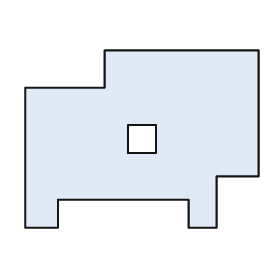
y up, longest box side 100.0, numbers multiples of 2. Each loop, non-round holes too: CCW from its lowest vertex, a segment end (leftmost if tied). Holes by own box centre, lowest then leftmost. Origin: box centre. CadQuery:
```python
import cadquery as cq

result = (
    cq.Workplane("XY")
    .moveTo(-50.0, -38.0)
    .lineTo(-36.0, -38.0)
    .lineTo(-36.0, -26.0)
    .lineTo(20.0, -26.0)
    .lineTo(20.0, -38.0)
    .lineTo(32.0, -38.0)
    .lineTo(32.0, -16.0)
    .lineTo(50.0, -16.0)
    .lineTo(50.0, 38.0)
    .lineTo(-16.0, 38.0)
    .lineTo(-16.0, 22.0)
    .lineTo(-50.0, 22.0)
    .close()
    .moveTo(-6.0, -6.0)
    .lineTo(6.0, -6.0)
    .lineTo(6.0, 6.0)
    .lineTo(-6.0, 6.0)
    .close()
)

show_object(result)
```